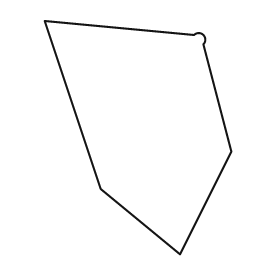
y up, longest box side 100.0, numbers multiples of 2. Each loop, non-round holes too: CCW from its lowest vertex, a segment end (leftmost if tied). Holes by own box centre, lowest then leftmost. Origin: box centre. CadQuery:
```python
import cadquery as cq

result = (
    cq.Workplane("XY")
    .moveTo(18.0, -50.0)
    .lineTo(40.0, -6.0)
    .lineTo(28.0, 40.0)
    .threePointArc((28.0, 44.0), (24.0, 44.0))
    .lineTo(-40.0, 50.0)
    .lineTo(-16.0, -22.0)
    .close()
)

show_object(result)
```